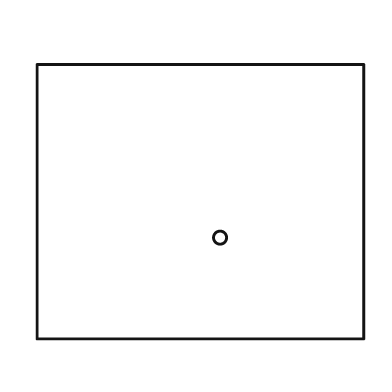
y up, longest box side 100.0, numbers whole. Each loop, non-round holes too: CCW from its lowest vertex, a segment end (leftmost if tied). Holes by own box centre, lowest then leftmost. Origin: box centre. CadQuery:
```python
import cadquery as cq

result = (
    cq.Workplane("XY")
    .moveTo(-50.0, -42.0)
    .lineTo(50.0, -42.0)
    .lineTo(50.0, 42.0)
    .lineTo(-50.0, 42.0)
    .close()
    .moveTo(6.0, -11.0)
    .circle(2.0)
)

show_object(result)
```